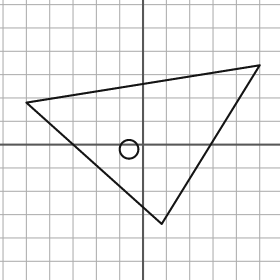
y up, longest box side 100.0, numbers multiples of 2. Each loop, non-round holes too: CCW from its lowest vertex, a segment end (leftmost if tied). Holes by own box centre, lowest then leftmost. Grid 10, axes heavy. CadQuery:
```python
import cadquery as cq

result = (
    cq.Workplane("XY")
    .moveTo(8.0, -34.0)
    .lineTo(50.0, 34.0)
    .lineTo(-50.0, 18.0)
    .close()
    .moveTo(-6.0, -2.0)
    .circle(4.0)
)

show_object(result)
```